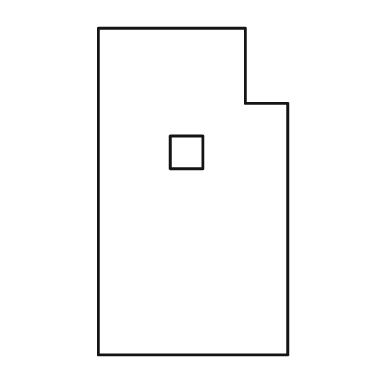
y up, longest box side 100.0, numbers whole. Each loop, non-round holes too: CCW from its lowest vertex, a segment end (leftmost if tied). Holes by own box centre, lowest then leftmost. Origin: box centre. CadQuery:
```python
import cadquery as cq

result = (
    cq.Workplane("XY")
    .moveTo(-29.0, -50.0)
    .lineTo(29.0, -50.0)
    .lineTo(29.0, 27.0)
    .lineTo(16.0, 27.0)
    .lineTo(16.0, 50.0)
    .lineTo(-29.0, 50.0)
    .close()
    .moveTo(-7.0, 7.0)
    .lineTo(3.0, 7.0)
    .lineTo(3.0, 17.0)
    .lineTo(-7.0, 17.0)
    .close()
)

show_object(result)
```